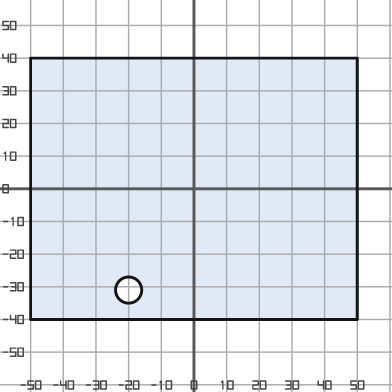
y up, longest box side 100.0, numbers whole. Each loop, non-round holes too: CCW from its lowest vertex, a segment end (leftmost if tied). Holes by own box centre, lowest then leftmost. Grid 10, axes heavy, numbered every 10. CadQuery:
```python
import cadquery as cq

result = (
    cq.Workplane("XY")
    .moveTo(-50.0, -40.0)
    .lineTo(50.0, -40.0)
    .lineTo(50.0, 40.0)
    .lineTo(-50.0, 40.0)
    .close()
    .moveTo(-20.0, -31.0)
    .circle(4.0)
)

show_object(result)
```